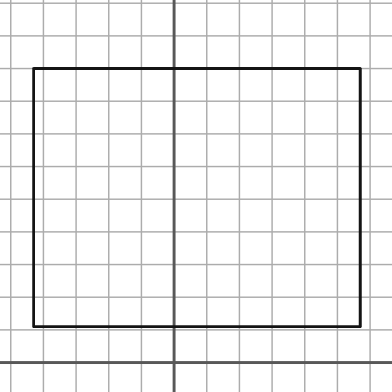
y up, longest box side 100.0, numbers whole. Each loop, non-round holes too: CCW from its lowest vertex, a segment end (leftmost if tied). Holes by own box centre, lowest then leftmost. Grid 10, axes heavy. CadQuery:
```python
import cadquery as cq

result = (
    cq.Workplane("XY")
    .moveTo(-43.0, 11.0)
    .lineTo(57.0, 11.0)
    .lineTo(57.0, 90.0)
    .lineTo(-43.0, 90.0)
    .close()
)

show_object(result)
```